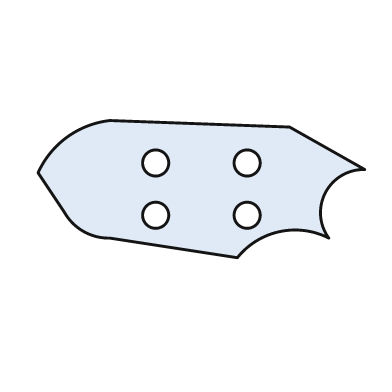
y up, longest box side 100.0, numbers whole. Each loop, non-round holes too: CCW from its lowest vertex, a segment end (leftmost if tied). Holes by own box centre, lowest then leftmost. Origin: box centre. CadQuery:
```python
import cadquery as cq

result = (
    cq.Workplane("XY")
    .moveTo(11.0, -21.0)
    .threePointArc((24.0, -13.0), (39.0, -15.0))
    .threePointArc((38.0, -1.0), (50.0, 6.0))
    .lineTo(27.0, 19.0)
    .lineTo(-28.0, 21.0)
    .threePointArc((-41.0, 16.0), (-50.0, 5.0))
    .lineTo(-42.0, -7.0)
    .threePointArc((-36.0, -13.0), (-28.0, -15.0))
    .close()
    .moveTo(-14.0, -8.0)
    .circle(4.0)
    .moveTo(14.0, -8.0)
    .circle(4.0)
    .moveTo(-14.0, 8.0)
    .circle(4.0)
    .moveTo(14.0, 8.0)
    .circle(4.0)
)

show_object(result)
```